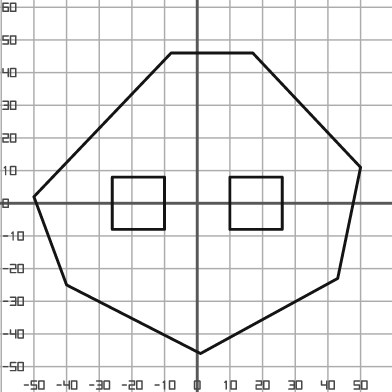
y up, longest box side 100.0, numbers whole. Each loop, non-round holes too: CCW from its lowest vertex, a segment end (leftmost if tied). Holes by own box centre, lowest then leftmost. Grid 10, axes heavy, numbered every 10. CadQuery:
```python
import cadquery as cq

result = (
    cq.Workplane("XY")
    .moveTo(1.0, -46.0)
    .lineTo(43.0, -23.0)
    .lineTo(50.0, 11.0)
    .lineTo(17.0, 46.0)
    .lineTo(-8.0, 46.0)
    .lineTo(-50.0, 2.0)
    .lineTo(-40.0, -25.0)
    .close()
    .moveTo(-26.0, -8.0)
    .lineTo(-10.0, -8.0)
    .lineTo(-10.0, 8.0)
    .lineTo(-26.0, 8.0)
    .close()
    .moveTo(10.0, -8.0)
    .lineTo(26.0, -8.0)
    .lineTo(26.0, 8.0)
    .lineTo(10.0, 8.0)
    .close()
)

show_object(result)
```